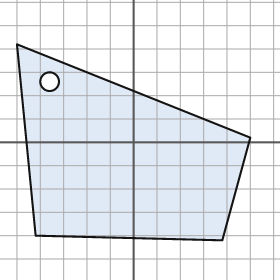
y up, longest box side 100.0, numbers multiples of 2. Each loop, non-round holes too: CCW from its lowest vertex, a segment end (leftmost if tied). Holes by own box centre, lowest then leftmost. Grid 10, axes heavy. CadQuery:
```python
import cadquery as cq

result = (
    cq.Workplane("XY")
    .moveTo(38.0, -42.0)
    .lineTo(50.0, 2.0)
    .lineTo(-50.0, 42.0)
    .lineTo(-42.0, -40.0)
    .close()
    .moveTo(-36.0, 26.0)
    .circle(4.0)
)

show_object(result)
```